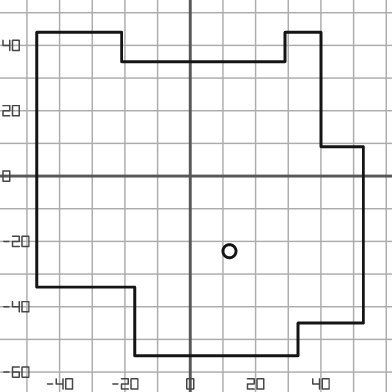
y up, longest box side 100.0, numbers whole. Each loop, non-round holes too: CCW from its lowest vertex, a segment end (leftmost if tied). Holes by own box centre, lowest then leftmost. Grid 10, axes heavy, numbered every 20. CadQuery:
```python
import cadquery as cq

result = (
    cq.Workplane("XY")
    .moveTo(-17.0, -55.0)
    .lineTo(33.0, -55.0)
    .lineTo(33.0, -45.0)
    .lineTo(53.0, -45.0)
    .lineTo(53.0, 9.0)
    .lineTo(40.0, 9.0)
    .lineTo(40.0, 44.0)
    .lineTo(29.0, 44.0)
    .lineTo(29.0, 35.0)
    .lineTo(-21.0, 35.0)
    .lineTo(-21.0, 44.0)
    .lineTo(-47.0, 44.0)
    .lineTo(-47.0, -34.0)
    .lineTo(-17.0, -34.0)
    .close()
    .moveTo(12.0, -23.0)
    .circle(2.0)
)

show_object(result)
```